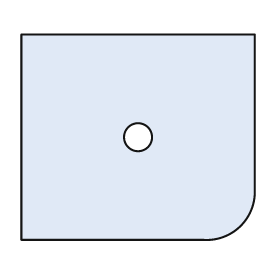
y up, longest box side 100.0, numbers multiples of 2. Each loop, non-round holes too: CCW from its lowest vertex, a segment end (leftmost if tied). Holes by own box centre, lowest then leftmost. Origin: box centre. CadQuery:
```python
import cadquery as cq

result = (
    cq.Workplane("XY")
    .moveTo(-50.0, -44.0)
    .lineTo(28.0, -44.0)
    .threePointArc((44.0, -38.0), (50.0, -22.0))
    .lineTo(50.0, 44.0)
    .lineTo(-50.0, 44.0)
    .close()
    .moveTo(0.0, 0.0)
    .circle(6.0)
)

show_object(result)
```